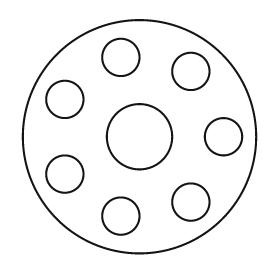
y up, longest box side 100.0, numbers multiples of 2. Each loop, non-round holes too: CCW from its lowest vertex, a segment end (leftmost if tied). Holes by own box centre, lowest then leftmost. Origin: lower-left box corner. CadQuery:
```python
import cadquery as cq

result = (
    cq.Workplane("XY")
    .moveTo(50.0, 50.0)
    .circle(50.0)
    .moveTo(42.0, 16.0)
    .circle(8.0)
    .moveTo(72.0, 22.0)
    .circle(8.0)
    .moveTo(18.0, 34.0)
    .circle(8.0)
    .moveTo(50.0, 50.0)
    .circle(14.0)
    .moveTo(86.0, 50.0)
    .circle(8.0)
    .moveTo(18.0, 66.0)
    .circle(8.0)
    .moveTo(72.0, 78.0)
    .circle(8.0)
    .moveTo(42.0, 84.0)
    .circle(8.0)
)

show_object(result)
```